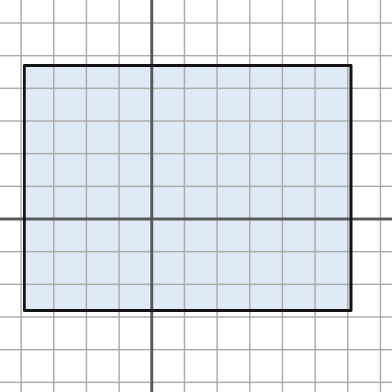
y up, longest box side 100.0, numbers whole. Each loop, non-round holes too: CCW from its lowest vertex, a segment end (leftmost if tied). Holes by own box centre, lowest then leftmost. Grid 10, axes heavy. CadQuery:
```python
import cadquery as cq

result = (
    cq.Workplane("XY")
    .moveTo(-39.0, -28.0)
    .lineTo(61.0, -28.0)
    .lineTo(61.0, 47.0)
    .lineTo(-39.0, 47.0)
    .close()
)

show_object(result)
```